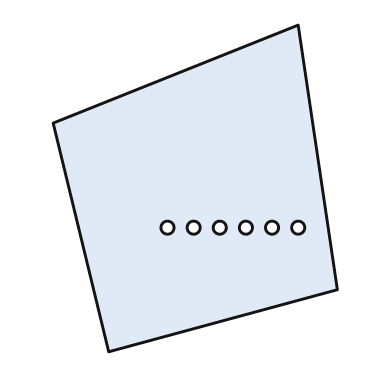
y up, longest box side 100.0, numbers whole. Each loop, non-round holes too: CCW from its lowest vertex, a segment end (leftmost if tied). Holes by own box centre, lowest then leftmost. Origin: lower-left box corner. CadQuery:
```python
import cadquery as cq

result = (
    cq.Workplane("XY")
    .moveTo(17.0, 0.0)
    .lineTo(87.0, 19.0)
    .lineTo(75.0, 100.0)
    .lineTo(0.0, 70.0)
    .close()
    .moveTo(35.0, 38.0)
    .circle(2.0)
    .moveTo(43.0, 38.0)
    .circle(2.0)
    .moveTo(51.0, 38.0)
    .circle(2.0)
    .moveTo(59.0, 38.0)
    .circle(2.0)
    .moveTo(67.0, 38.0)
    .circle(2.0)
    .moveTo(75.0, 38.0)
    .circle(2.0)
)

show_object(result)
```